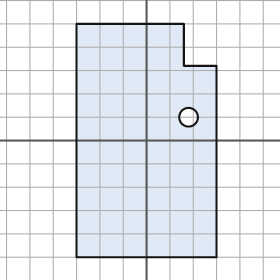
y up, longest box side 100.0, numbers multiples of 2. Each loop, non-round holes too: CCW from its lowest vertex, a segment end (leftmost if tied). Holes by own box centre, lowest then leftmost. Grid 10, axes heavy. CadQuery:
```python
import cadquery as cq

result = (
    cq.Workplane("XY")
    .moveTo(-30.0, -50.0)
    .lineTo(30.0, -50.0)
    .lineTo(30.0, 32.0)
    .lineTo(16.0, 32.0)
    .lineTo(16.0, 50.0)
    .lineTo(-30.0, 50.0)
    .close()
    .moveTo(18.0, 10.0)
    .circle(4.0)
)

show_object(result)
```